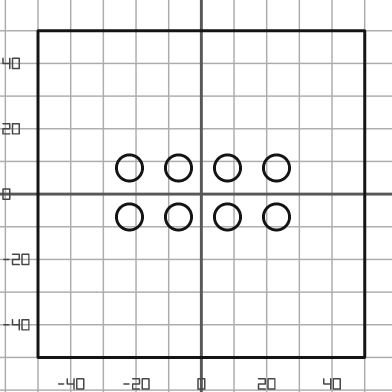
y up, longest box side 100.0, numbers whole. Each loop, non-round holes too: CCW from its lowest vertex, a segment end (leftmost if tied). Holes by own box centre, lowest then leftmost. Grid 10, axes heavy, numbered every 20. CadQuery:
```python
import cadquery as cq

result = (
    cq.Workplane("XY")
    .moveTo(-50.0, -50.0)
    .lineTo(50.0, -50.0)
    .lineTo(50.0, 50.0)
    .lineTo(-50.0, 50.0)
    .close()
    .moveTo(-22.0, -7.0)
    .circle(4.0)
    .moveTo(-7.0, -7.0)
    .circle(4.0)
    .moveTo(8.0, -7.0)
    .circle(4.0)
    .moveTo(23.0, -7.0)
    .circle(4.0)
    .moveTo(-22.0, 8.0)
    .circle(4.0)
    .moveTo(-7.0, 8.0)
    .circle(4.0)
    .moveTo(8.0, 8.0)
    .circle(4.0)
    .moveTo(23.0, 8.0)
    .circle(4.0)
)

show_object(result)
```